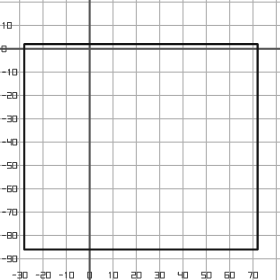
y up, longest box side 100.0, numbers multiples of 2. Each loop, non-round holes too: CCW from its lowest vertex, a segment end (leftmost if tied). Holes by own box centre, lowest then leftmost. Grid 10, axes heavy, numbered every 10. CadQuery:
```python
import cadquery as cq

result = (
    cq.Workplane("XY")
    .moveTo(-28.0, -86.0)
    .lineTo(72.0, -86.0)
    .lineTo(72.0, 2.0)
    .lineTo(-28.0, 2.0)
    .close()
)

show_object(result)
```